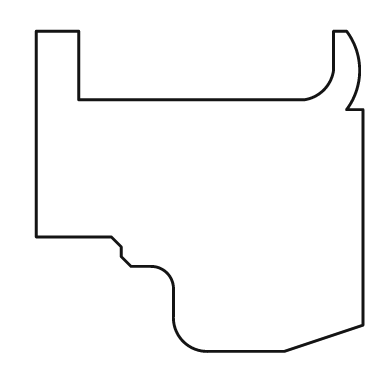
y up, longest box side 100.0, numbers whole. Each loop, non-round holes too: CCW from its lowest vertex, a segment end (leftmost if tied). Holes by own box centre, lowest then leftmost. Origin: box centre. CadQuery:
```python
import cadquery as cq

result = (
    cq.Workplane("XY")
    .moveTo(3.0, -49.0)
    .lineTo(26.0, -49.0)
    .lineTo(50.0, -41.0)
    .lineTo(50.0, 25.0)
    .lineTo(45.0, 25.0)
    .threePointArc((49.0, 37.0), (45.0, 49.0))
    .lineTo(41.0, 49.0)
    .lineTo(41.0, 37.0)
    .threePointArc((38.0, 31.0), (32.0, 28.0))
    .lineTo(-37.0, 28.0)
    .lineTo(-37.0, 49.0)
    .lineTo(-50.0, 49.0)
    .lineTo(-50.0, -14.0)
    .lineTo(-27.0, -14.0)
    .lineTo(-24.0, -17.0)
    .lineTo(-24.0, -20.0)
    .lineTo(-21.0, -23.0)
    .lineTo(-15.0, -23.0)
    .threePointArc((-10.0, -25.0), (-8.0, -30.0))
    .lineTo(-8.0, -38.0)
    .threePointArc((-5.0, -46.0), (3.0, -49.0))
    .close()
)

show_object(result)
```